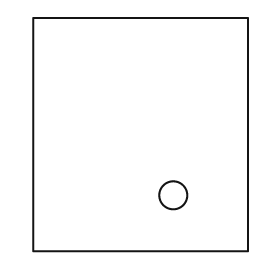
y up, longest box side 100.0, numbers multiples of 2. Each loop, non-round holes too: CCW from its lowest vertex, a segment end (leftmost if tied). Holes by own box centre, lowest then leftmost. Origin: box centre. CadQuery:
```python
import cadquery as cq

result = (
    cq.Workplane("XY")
    .moveTo(-46.0, -50.0)
    .lineTo(46.0, -50.0)
    .lineTo(46.0, 50.0)
    .lineTo(-46.0, 50.0)
    .close()
    .moveTo(14.0, -26.0)
    .circle(6.0)
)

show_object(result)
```